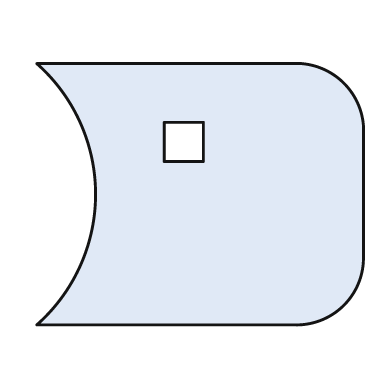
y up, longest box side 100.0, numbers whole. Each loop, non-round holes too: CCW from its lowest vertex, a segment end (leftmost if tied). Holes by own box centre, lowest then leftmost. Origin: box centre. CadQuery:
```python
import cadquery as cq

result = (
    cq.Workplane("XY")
    .moveTo(-50.0, -40.0)
    .lineTo(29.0, -40.0)
    .threePointArc((44.0, -34.0), (50.0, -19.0))
    .lineTo(50.0, 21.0)
    .threePointArc((44.0, 34.0), (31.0, 40.0))
    .lineTo(-50.0, 40.0)
    .threePointArc((-32.0, 0.0), (-50.0, -40.0))
    .close()
    .moveTo(-11.0, 10.0)
    .lineTo(1.0, 10.0)
    .lineTo(1.0, 22.0)
    .lineTo(-11.0, 22.0)
    .close()
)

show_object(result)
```